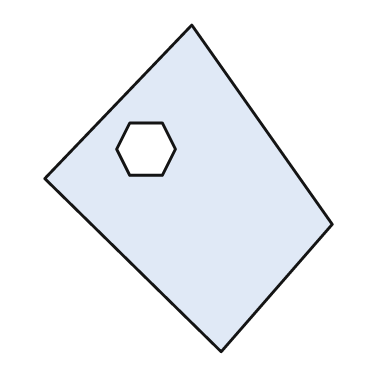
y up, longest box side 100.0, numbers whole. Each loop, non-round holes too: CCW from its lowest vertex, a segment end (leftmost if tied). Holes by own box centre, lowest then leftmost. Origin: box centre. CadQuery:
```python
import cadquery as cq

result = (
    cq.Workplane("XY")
    .moveTo(10.0, -50.0)
    .lineTo(44.0, -11.0)
    .lineTo(1.0, 50.0)
    .lineTo(-44.0, 3.0)
    .close()
    .moveTo(-18.0, 4.0)
    .lineTo(-8.0, 4.0)
    .lineTo(-4.0, 12.0)
    .lineTo(-8.0, 20.0)
    .lineTo(-18.0, 20.0)
    .lineTo(-22.0, 12.0)
    .close()
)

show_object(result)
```